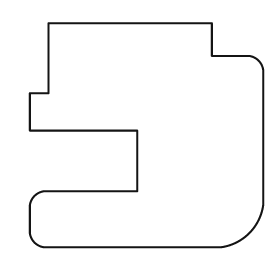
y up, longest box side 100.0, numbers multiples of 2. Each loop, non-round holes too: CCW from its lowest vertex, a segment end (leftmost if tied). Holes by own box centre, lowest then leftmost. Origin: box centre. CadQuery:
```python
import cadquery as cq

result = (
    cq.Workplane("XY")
    .moveTo(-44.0, -48.0)
    .lineTo(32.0, -48.0)
    .threePointArc((44.0, -42.0), (50.0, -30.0))
    .lineTo(50.0, 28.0)
    .threePointArc((48.0, 32.0), (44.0, 34.0))
    .lineTo(28.0, 34.0)
    .lineTo(28.0, 48.0)
    .lineTo(-42.0, 48.0)
    .lineTo(-42.0, 18.0)
    .lineTo(-50.0, 18.0)
    .lineTo(-50.0, 2.0)
    .lineTo(-4.0, 2.0)
    .lineTo(-4.0, -24.0)
    .lineTo(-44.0, -24.0)
    .threePointArc((-48.0, -26.0), (-50.0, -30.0))
    .lineTo(-50.0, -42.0)
    .threePointArc((-48.0, -46.0), (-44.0, -48.0))
    .close()
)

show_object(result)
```